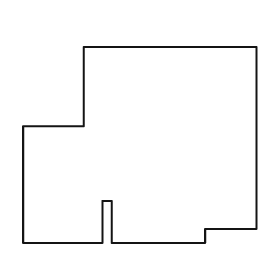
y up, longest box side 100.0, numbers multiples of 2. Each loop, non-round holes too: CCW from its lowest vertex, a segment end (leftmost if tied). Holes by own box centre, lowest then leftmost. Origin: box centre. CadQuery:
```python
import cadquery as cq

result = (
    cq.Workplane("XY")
    .moveTo(-50.0, -42.0)
    .lineTo(-16.0, -42.0)
    .lineTo(-16.0, -24.0)
    .lineTo(-12.0, -24.0)
    .lineTo(-12.0, -42.0)
    .lineTo(28.0, -42.0)
    .lineTo(28.0, -36.0)
    .lineTo(50.0, -36.0)
    .lineTo(50.0, 42.0)
    .lineTo(-24.0, 42.0)
    .lineTo(-24.0, 8.0)
    .lineTo(-50.0, 8.0)
    .close()
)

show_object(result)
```